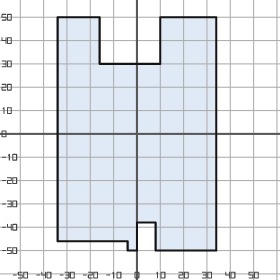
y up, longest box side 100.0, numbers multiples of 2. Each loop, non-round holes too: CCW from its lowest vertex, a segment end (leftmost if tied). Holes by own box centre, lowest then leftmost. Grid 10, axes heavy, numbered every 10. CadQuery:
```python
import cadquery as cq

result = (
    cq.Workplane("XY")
    .moveTo(-4.0, -50.0)
    .lineTo(0.0, -50.0)
    .lineTo(0.0, -38.0)
    .lineTo(8.0, -38.0)
    .lineTo(8.0, -50.0)
    .lineTo(34.0, -50.0)
    .lineTo(34.0, 50.0)
    .lineTo(10.0, 50.0)
    .lineTo(10.0, 30.0)
    .lineTo(-16.0, 30.0)
    .lineTo(-16.0, 50.0)
    .lineTo(-34.0, 50.0)
    .lineTo(-34.0, -46.0)
    .lineTo(-4.0, -46.0)
    .close()
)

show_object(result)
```